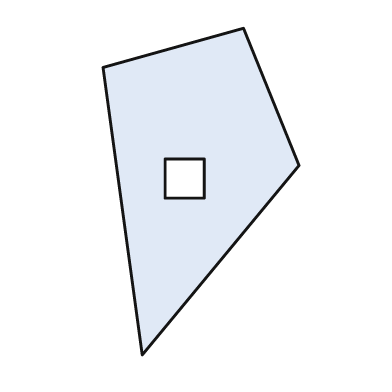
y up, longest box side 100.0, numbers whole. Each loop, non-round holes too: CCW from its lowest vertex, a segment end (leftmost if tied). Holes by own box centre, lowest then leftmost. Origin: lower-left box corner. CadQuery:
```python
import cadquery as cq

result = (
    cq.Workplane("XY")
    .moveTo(12.0, 0.0)
    .lineTo(60.0, 58.0)
    .lineTo(43.0, 100.0)
    .lineTo(0.0, 88.0)
    .close()
    .moveTo(19.0, 48.0)
    .lineTo(31.0, 48.0)
    .lineTo(31.0, 60.0)
    .lineTo(19.0, 60.0)
    .close()
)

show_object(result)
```